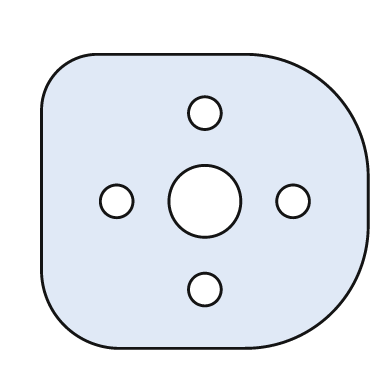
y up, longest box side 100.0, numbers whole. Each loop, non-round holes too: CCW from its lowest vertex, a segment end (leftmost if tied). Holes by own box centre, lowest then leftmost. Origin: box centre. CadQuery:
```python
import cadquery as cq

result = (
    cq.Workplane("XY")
    .moveTo(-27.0, -45.0)
    .lineTo(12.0, -45.0)
    .threePointArc((39.0, -34.0), (50.0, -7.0))
    .lineTo(50.0, 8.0)
    .threePointArc((39.0, 34.0), (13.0, 45.0))
    .lineTo(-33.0, 45.0)
    .threePointArc((-45.0, 40.0), (-50.0, 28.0))
    .lineTo(-50.0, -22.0)
    .threePointArc((-43.0, -38.0), (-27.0, -45.0))
    .close()
    .moveTo(0.0, -27.0)
    .circle(5.0)
    .moveTo(-27.0, 0.0)
    .circle(5.0)
    .moveTo(0.0, 0.0)
    .circle(11.0)
    .moveTo(27.0, 0.0)
    .circle(5.0)
    .moveTo(0.0, 27.0)
    .circle(5.0)
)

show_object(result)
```